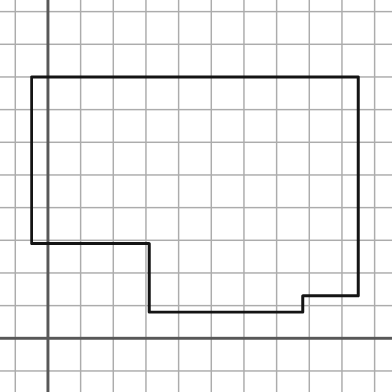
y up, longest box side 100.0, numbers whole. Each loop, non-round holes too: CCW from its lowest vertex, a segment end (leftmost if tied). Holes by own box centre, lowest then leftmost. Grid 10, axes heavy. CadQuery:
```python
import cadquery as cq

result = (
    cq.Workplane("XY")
    .moveTo(31.0, 8.0)
    .lineTo(78.0, 8.0)
    .lineTo(78.0, 13.0)
    .lineTo(95.0, 13.0)
    .lineTo(95.0, 80.0)
    .lineTo(-5.0, 80.0)
    .lineTo(-5.0, 29.0)
    .lineTo(31.0, 29.0)
    .close()
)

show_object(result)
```